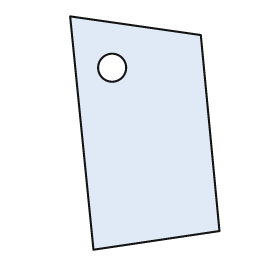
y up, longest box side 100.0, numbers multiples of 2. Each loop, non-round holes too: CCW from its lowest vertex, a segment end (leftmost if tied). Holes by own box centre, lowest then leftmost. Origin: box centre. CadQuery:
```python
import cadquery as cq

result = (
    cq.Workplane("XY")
    .moveTo(-22.0, -50.0)
    .lineTo(32.0, -42.0)
    .lineTo(24.0, 42.0)
    .lineTo(-32.0, 50.0)
    .close()
    .moveTo(-14.0, 28.0)
    .circle(6.0)
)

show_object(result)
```